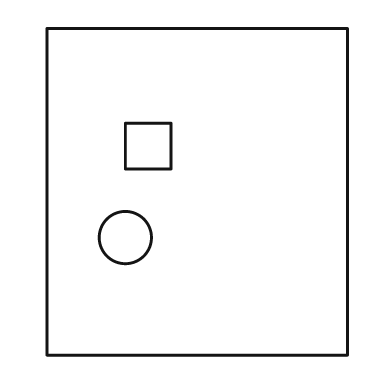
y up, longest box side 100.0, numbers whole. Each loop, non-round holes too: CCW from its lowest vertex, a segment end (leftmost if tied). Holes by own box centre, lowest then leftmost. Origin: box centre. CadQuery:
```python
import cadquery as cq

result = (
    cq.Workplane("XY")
    .moveTo(-46.0, -50.0)
    .lineTo(46.0, -50.0)
    .lineTo(46.0, 50.0)
    .lineTo(-46.0, 50.0)
    .close()
    .moveTo(-22.0, -14.0)
    .circle(8.0)
    .moveTo(-22.0, 7.0)
    .lineTo(-8.0, 7.0)
    .lineTo(-8.0, 21.0)
    .lineTo(-22.0, 21.0)
    .close()
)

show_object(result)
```